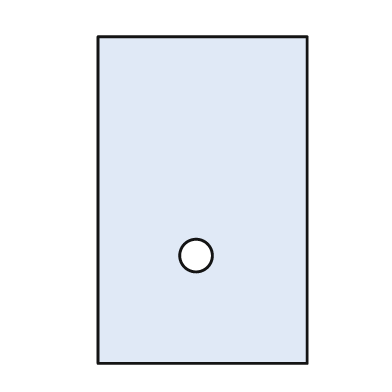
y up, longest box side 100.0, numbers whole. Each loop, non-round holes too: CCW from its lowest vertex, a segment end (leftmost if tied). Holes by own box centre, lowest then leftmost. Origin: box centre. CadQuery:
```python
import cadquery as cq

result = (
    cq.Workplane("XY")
    .moveTo(-32.0, -50.0)
    .lineTo(32.0, -50.0)
    .lineTo(32.0, 50.0)
    .lineTo(-32.0, 50.0)
    .close()
    .moveTo(-2.0, -17.0)
    .circle(5.0)
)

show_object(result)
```